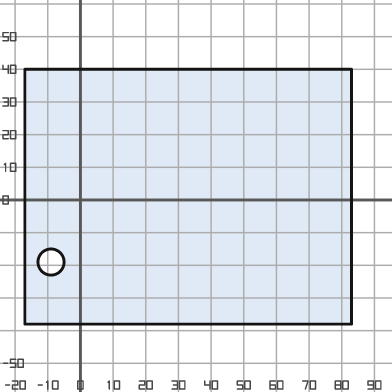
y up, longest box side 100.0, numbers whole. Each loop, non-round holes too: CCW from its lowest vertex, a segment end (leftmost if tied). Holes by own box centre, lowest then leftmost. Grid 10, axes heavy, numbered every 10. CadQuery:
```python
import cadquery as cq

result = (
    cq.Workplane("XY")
    .moveTo(-17.0, -38.0)
    .lineTo(83.0, -38.0)
    .lineTo(83.0, 40.0)
    .lineTo(-17.0, 40.0)
    .close()
    .moveTo(-9.0, -19.0)
    .circle(4.0)
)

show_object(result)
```